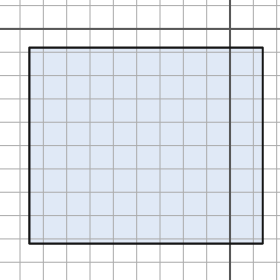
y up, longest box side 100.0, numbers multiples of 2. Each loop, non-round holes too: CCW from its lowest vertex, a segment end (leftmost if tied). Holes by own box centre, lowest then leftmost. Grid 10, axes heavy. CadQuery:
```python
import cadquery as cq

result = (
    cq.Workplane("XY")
    .moveTo(-86.0, -92.0)
    .lineTo(14.0, -92.0)
    .lineTo(14.0, -8.0)
    .lineTo(-86.0, -8.0)
    .close()
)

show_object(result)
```